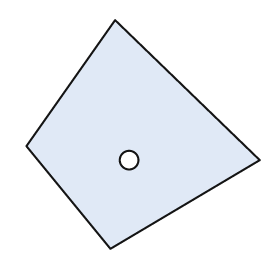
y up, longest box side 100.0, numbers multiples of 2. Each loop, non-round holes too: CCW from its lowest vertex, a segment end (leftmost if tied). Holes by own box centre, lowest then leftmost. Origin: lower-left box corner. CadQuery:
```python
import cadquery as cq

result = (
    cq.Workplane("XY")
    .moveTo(36.0, 0.0)
    .lineTo(100.0, 38.0)
    .lineTo(38.0, 98.0)
    .lineTo(0.0, 44.0)
    .close()
    .moveTo(44.0, 38.0)
    .circle(4.0)
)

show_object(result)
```